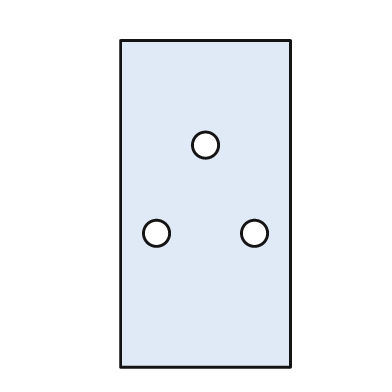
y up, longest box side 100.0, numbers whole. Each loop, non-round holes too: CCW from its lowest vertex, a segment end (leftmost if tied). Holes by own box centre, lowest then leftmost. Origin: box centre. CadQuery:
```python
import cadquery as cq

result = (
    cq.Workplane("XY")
    .moveTo(-26.0, -50.0)
    .lineTo(26.0, -50.0)
    .lineTo(26.0, 50.0)
    .lineTo(-26.0, 50.0)
    .close()
    .moveTo(-15.0, -9.0)
    .circle(4.0)
    .moveTo(15.0, -9.0)
    .circle(4.0)
    .moveTo(0.0, 18.0)
    .circle(4.0)
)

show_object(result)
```